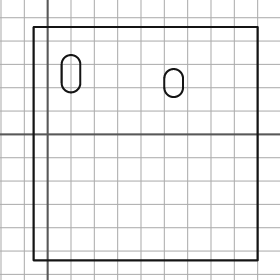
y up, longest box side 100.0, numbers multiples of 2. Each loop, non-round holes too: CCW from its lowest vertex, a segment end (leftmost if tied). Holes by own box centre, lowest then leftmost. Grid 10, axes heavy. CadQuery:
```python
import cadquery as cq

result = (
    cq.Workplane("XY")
    .moveTo(-6.0, -54.0)
    .lineTo(90.0, -54.0)
    .lineTo(90.0, 46.0)
    .lineTo(-6.0, 46.0)
    .close()
    .moveTo(50.0, 20.0)
    .threePointArc((54.0, 16.0), (58.0, 20.0))
    .lineTo(58.0, 24.0)
    .threePointArc((54.0, 28.0), (50.0, 24.0))
    .close()
    .moveTo(6.0, 22.0)
    .threePointArc((10.0, 18.0), (14.0, 22.0))
    .lineTo(14.0, 30.0)
    .threePointArc((10.0, 34.0), (6.0, 30.0))
    .close()
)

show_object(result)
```